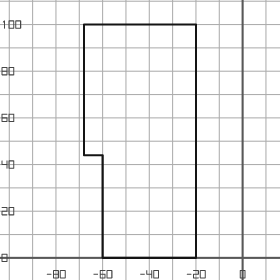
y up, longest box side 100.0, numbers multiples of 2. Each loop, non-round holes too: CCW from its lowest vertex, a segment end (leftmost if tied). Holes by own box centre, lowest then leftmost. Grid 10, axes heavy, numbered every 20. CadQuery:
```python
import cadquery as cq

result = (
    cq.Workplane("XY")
    .moveTo(-60.0, 0.0)
    .lineTo(-20.0, 0.0)
    .lineTo(-20.0, 100.0)
    .lineTo(-68.0, 100.0)
    .lineTo(-68.0, 44.0)
    .lineTo(-60.0, 44.0)
    .close()
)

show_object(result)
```